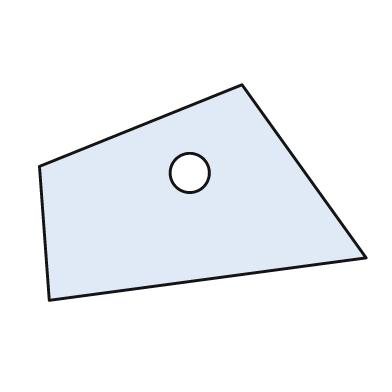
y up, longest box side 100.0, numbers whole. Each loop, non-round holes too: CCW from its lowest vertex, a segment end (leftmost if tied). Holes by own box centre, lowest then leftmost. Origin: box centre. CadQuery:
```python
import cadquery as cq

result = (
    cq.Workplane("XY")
    .moveTo(-47.0, -33.0)
    .lineTo(50.0, -20.0)
    .lineTo(12.0, 33.0)
    .lineTo(-50.0, 8.0)
    .close()
    .moveTo(-4.0, 6.0)
    .circle(6.0)
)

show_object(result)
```